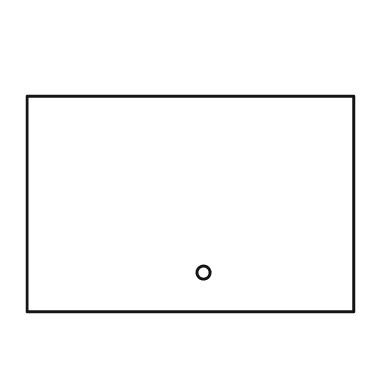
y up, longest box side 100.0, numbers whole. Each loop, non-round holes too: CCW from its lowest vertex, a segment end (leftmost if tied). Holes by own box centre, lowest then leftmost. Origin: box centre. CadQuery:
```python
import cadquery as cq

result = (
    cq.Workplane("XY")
    .moveTo(-50.0, -33.0)
    .lineTo(50.0, -33.0)
    .lineTo(50.0, 33.0)
    .lineTo(-50.0, 33.0)
    .close()
    .moveTo(4.0, -21.0)
    .circle(2.0)
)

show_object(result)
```